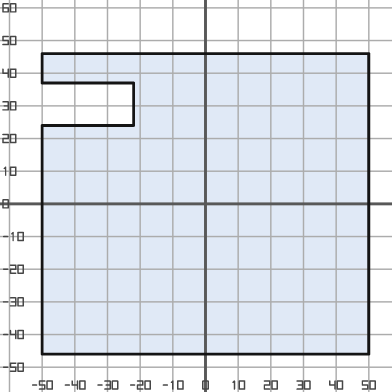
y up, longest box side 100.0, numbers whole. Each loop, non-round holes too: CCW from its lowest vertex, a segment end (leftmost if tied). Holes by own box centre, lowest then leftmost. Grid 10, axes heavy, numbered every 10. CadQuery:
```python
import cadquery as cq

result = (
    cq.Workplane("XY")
    .moveTo(-50.0, -46.0)
    .lineTo(50.0, -46.0)
    .lineTo(50.0, 46.0)
    .lineTo(-50.0, 46.0)
    .lineTo(-50.0, 37.0)
    .lineTo(-22.0, 37.0)
    .lineTo(-22.0, 24.0)
    .lineTo(-50.0, 24.0)
    .close()
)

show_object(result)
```